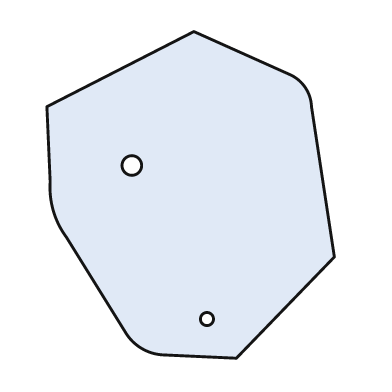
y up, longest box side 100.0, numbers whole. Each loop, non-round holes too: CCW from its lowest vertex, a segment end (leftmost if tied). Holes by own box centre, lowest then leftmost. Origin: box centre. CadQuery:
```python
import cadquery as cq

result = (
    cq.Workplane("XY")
    .moveTo(14.0, -50.0)
    .lineTo(44.0, -19.0)
    .lineTo(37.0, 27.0)
    .threePointArc((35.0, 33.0), (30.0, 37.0))
    .lineTo(1.0, 50.0)
    .lineTo(-44.0, 27.0)
    .lineTo(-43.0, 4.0)
    .threePointArc((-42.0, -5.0), (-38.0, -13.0))
    .lineTo(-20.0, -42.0)
    .threePointArc((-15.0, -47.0), (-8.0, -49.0))
    .close()
    .moveTo(5.0, -38.0)
    .circle(2.0)
    .moveTo(-18.0, 9.0)
    .circle(3.0)
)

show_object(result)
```